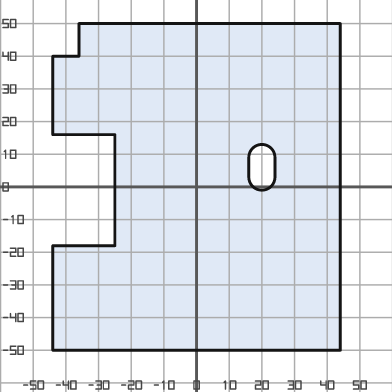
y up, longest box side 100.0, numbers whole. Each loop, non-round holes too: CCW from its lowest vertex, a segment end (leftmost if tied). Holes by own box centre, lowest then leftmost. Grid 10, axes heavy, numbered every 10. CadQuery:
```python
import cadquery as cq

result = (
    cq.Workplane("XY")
    .moveTo(-44.0, -50.0)
    .lineTo(44.0, -50.0)
    .lineTo(44.0, 50.0)
    .lineTo(-36.0, 50.0)
    .lineTo(-36.0, 40.0)
    .lineTo(-44.0, 40.0)
    .lineTo(-44.0, 16.0)
    .lineTo(-25.0, 16.0)
    .lineTo(-25.0, -18.0)
    .lineTo(-44.0, -18.0)
    .close()
    .moveTo(16.0, 3.0)
    .threePointArc((20.0, -1.0), (24.0, 3.0))
    .lineTo(24.0, 9.0)
    .threePointArc((20.0, 13.0), (16.0, 9.0))
    .close()
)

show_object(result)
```